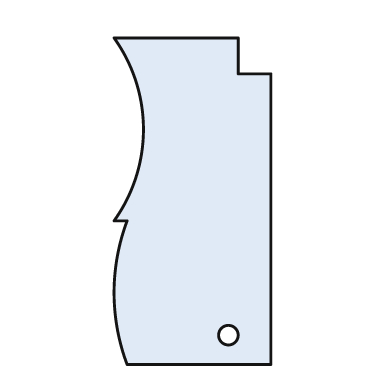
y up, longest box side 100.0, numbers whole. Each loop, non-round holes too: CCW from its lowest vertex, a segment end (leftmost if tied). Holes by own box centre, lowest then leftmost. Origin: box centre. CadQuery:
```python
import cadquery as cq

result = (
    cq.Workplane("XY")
    .moveTo(-20.0, -50.0)
    .lineTo(24.0, -50.0)
    .lineTo(24.0, 39.0)
    .lineTo(14.0, 39.0)
    .lineTo(14.0, 50.0)
    .lineTo(-24.0, 50.0)
    .threePointArc((-15.0, 22.0), (-24.0, -6.0))
    .lineTo(-20.0, -6.0)
    .threePointArc((-24.0, -28.0), (-20.0, -50.0))
    .close()
    .moveTo(11.0, -41.0)
    .circle(3.0)
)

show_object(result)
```